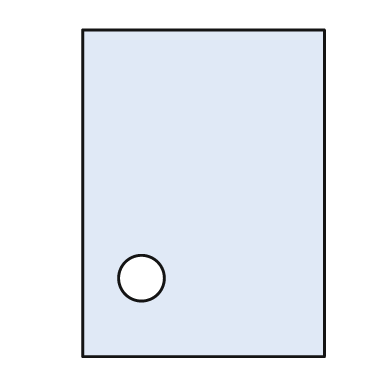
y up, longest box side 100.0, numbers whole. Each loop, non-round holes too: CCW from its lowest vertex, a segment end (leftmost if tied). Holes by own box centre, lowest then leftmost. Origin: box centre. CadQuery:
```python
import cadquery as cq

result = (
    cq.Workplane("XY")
    .moveTo(-37.0, -50.0)
    .lineTo(37.0, -50.0)
    .lineTo(37.0, 50.0)
    .lineTo(-37.0, 50.0)
    .close()
    .moveTo(-19.0, -26.0)
    .circle(7.0)
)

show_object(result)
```